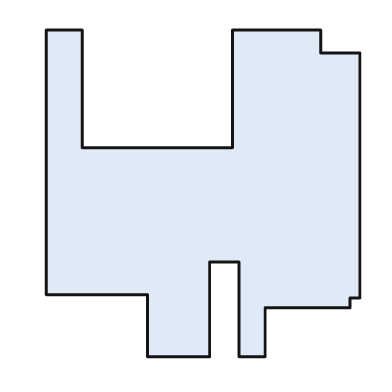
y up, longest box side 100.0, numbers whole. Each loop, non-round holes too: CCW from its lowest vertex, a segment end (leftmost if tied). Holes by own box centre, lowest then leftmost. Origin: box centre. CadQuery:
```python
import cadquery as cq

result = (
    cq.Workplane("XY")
    .moveTo(-17.0, -50.0)
    .lineTo(2.0, -50.0)
    .lineTo(2.0, -21.0)
    .lineTo(11.0, -21.0)
    .lineTo(11.0, -50.0)
    .lineTo(19.0, -50.0)
    .lineTo(19.0, -35.0)
    .lineTo(45.0, -35.0)
    .lineTo(45.0, -32.0)
    .lineTo(48.0, -32.0)
    .lineTo(48.0, 43.0)
    .lineTo(36.0, 43.0)
    .lineTo(36.0, 50.0)
    .lineTo(9.0, 50.0)
    .lineTo(9.0, 14.0)
    .lineTo(-37.0, 14.0)
    .lineTo(-37.0, 50.0)
    .lineTo(-48.0, 50.0)
    .lineTo(-48.0, -31.0)
    .lineTo(-17.0, -31.0)
    .close()
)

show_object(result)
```